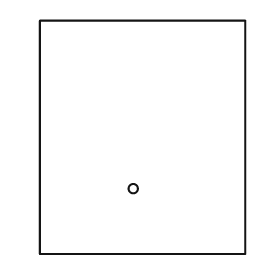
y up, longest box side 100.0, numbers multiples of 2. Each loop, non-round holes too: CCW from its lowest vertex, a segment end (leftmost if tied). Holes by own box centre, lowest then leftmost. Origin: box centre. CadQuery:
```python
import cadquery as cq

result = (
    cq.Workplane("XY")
    .moveTo(-44.0, -50.0)
    .lineTo(44.0, -50.0)
    .lineTo(44.0, 50.0)
    .lineTo(-44.0, 50.0)
    .close()
    .moveTo(-4.0, -22.0)
    .circle(2.0)
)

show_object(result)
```